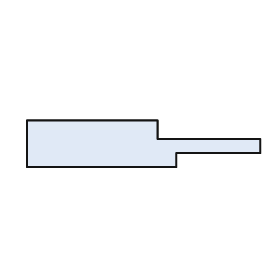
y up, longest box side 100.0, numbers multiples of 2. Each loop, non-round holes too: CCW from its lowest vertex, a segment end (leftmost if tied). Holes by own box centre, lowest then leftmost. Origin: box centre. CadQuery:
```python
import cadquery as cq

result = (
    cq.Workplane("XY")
    .moveTo(-50.0, -10.0)
    .lineTo(14.0, -10.0)
    .lineTo(14.0, -4.0)
    .lineTo(50.0, -4.0)
    .lineTo(50.0, 2.0)
    .lineTo(6.0, 2.0)
    .lineTo(6.0, 10.0)
    .lineTo(-50.0, 10.0)
    .close()
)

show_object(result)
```